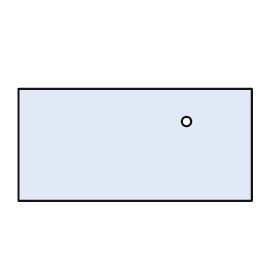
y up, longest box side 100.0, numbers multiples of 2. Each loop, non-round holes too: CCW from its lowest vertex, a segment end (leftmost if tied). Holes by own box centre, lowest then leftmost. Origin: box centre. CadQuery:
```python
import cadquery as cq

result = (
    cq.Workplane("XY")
    .moveTo(-50.0, -24.0)
    .lineTo(50.0, -24.0)
    .lineTo(50.0, 24.0)
    .lineTo(-50.0, 24.0)
    .close()
    .moveTo(22.0, 10.0)
    .circle(2.0)
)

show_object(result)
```